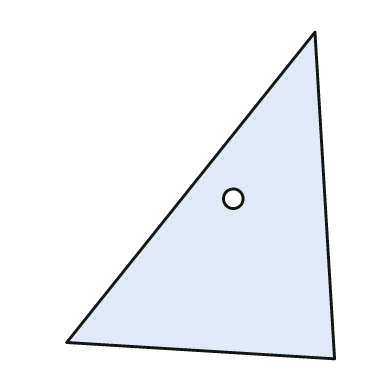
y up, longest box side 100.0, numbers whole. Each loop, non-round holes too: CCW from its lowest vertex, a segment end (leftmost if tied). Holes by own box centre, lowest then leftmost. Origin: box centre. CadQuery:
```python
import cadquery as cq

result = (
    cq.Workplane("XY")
    .moveTo(41.0, -50.0)
    .lineTo(35.0, 50.0)
    .lineTo(-41.0, -45.0)
    .close()
    .moveTo(10.0, -1.0)
    .circle(3.0)
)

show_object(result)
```